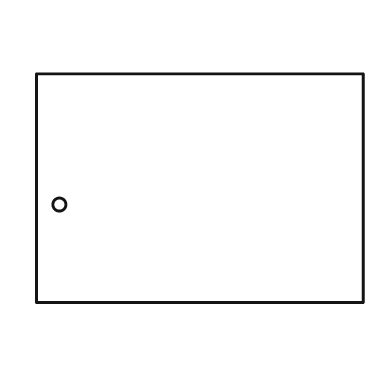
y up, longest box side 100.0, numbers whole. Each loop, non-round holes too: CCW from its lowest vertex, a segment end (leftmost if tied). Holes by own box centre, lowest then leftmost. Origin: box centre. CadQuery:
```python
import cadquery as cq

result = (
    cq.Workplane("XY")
    .moveTo(-50.0, -35.0)
    .lineTo(50.0, -35.0)
    .lineTo(50.0, 35.0)
    .lineTo(-50.0, 35.0)
    .close()
    .moveTo(-43.0, -5.0)
    .circle(2.0)
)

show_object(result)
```